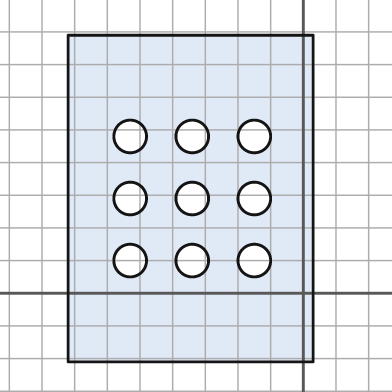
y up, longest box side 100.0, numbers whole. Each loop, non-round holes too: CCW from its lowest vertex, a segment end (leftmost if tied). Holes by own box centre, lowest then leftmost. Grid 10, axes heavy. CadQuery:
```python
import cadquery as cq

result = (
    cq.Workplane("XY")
    .moveTo(-72.0, -21.0)
    .lineTo(3.0, -21.0)
    .lineTo(3.0, 79.0)
    .lineTo(-72.0, 79.0)
    .close()
    .moveTo(-53.0, 10.0)
    .circle(5.0)
    .moveTo(-34.0, 10.0)
    .circle(5.0)
    .moveTo(-15.0, 10.0)
    .circle(5.0)
    .moveTo(-53.0, 29.0)
    .circle(5.0)
    .moveTo(-34.0, 29.0)
    .circle(5.0)
    .moveTo(-15.0, 29.0)
    .circle(5.0)
    .moveTo(-53.0, 48.0)
    .circle(5.0)
    .moveTo(-34.0, 48.0)
    .circle(5.0)
    .moveTo(-15.0, 48.0)
    .circle(5.0)
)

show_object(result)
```